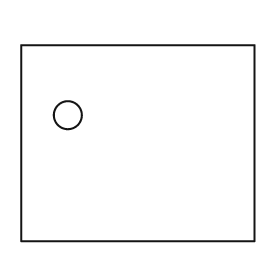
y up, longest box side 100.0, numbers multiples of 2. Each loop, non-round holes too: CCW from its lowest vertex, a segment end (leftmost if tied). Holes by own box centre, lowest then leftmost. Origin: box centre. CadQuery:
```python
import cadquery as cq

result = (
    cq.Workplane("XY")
    .moveTo(-50.0, -42.0)
    .lineTo(50.0, -42.0)
    .lineTo(50.0, 42.0)
    .lineTo(-50.0, 42.0)
    .close()
    .moveTo(-30.0, 12.0)
    .circle(6.0)
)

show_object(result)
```